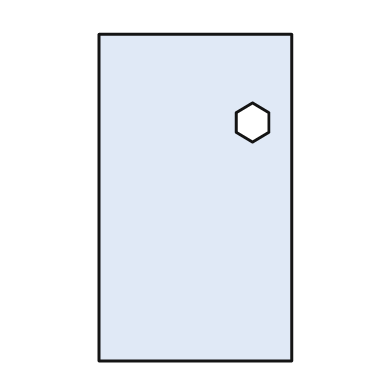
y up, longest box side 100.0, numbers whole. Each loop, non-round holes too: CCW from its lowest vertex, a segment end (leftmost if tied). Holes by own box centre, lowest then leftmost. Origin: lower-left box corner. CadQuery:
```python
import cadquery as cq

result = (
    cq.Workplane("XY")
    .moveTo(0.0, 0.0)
    .lineTo(59.0, 0.0)
    .lineTo(59.0, 100.0)
    .lineTo(0.0, 100.0)
    .close()
    .moveTo(47.0, 67.0)
    .lineTo(52.0, 70.0)
    .lineTo(52.0, 76.0)
    .lineTo(47.0, 79.0)
    .lineTo(42.0, 76.0)
    .lineTo(42.0, 70.0)
    .close()
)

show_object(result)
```